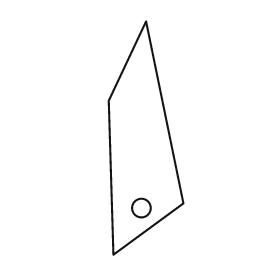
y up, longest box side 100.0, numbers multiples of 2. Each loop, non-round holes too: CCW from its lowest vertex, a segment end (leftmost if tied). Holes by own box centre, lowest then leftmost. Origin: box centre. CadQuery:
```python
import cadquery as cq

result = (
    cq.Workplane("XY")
    .moveTo(-14.0, -50.0)
    .lineTo(16.0, -28.0)
    .lineTo(0.0, 50.0)
    .lineTo(-16.0, 16.0)
    .close()
    .moveTo(-2.0, -30.0)
    .circle(4.0)
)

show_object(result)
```